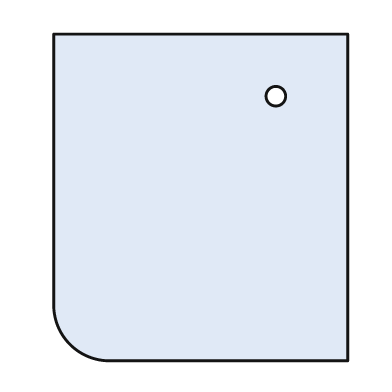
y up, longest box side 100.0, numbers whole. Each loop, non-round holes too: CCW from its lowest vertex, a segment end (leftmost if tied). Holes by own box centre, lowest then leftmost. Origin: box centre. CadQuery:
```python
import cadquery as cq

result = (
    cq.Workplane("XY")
    .moveTo(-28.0, -50.0)
    .lineTo(45.0, -50.0)
    .lineTo(45.0, 50.0)
    .lineTo(-45.0, 50.0)
    .lineTo(-45.0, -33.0)
    .threePointArc((-40.0, -45.0), (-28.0, -50.0))
    .close()
    .moveTo(23.0, 31.0)
    .circle(3.0)
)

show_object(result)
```